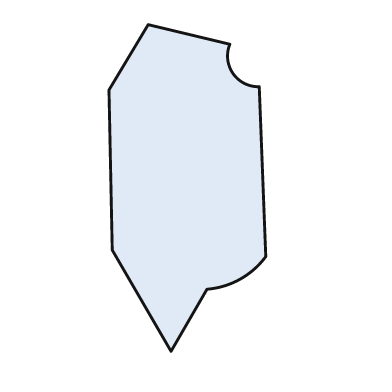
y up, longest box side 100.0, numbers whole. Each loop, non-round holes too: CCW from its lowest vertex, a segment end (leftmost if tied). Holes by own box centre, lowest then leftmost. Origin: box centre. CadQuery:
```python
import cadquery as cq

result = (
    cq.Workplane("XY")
    .moveTo(-5.0, -50.0)
    .lineTo(6.0, -31.0)
    .threePointArc((16.0, -28.0), (24.0, -21.0))
    .lineTo(22.0, 31.0)
    .threePointArc((14.0, 35.0), (13.0, 44.0))
    .lineTo(-12.0, 50.0)
    .lineTo(-24.0, 30.0)
    .lineTo(-23.0, -19.0)
    .close()
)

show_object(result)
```